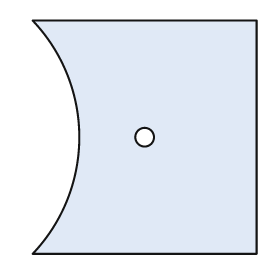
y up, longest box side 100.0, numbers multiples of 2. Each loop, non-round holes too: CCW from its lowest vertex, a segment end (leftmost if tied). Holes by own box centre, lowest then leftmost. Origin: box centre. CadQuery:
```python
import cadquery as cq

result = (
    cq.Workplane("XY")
    .moveTo(-48.0, -50.0)
    .lineTo(48.0, -50.0)
    .lineTo(48.0, 50.0)
    .lineTo(-48.0, 50.0)
    .threePointArc((-28.0, 0.0), (-48.0, -50.0))
    .close()
    .moveTo(0.0, 0.0)
    .circle(4.0)
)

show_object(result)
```